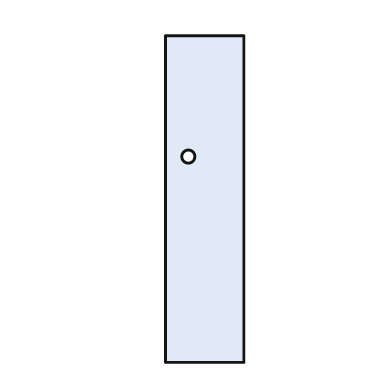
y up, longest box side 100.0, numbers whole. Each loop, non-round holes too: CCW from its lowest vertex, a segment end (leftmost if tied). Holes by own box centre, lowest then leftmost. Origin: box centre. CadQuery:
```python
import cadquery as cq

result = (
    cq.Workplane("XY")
    .moveTo(-12.0, -50.0)
    .lineTo(12.0, -50.0)
    .lineTo(12.0, 50.0)
    .lineTo(-12.0, 50.0)
    .close()
    .moveTo(-5.0, 13.0)
    .circle(2.0)
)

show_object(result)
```